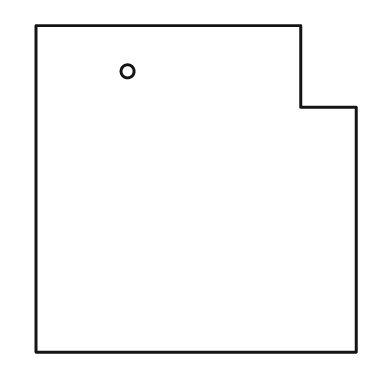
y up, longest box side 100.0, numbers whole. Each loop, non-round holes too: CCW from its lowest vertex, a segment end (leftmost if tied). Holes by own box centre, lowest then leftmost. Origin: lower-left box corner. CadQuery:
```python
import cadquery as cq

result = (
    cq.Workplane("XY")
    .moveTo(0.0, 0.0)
    .lineTo(98.0, 0.0)
    .lineTo(98.0, 75.0)
    .lineTo(81.0, 75.0)
    .lineTo(81.0, 100.0)
    .lineTo(0.0, 100.0)
    .close()
    .moveTo(28.0, 86.0)
    .circle(2.0)
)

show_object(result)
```